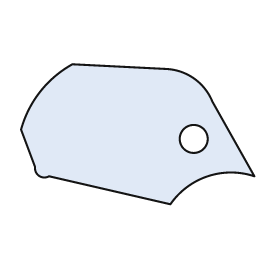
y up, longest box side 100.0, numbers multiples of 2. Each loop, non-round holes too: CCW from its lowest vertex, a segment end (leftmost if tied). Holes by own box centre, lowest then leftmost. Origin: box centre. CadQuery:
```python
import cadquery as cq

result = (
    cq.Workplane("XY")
    .moveTo(14.0, -30.0)
    .threePointArc((30.0, -18.0), (50.0, -18.0))
    .lineTo(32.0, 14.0)
    .threePointArc((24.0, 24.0), (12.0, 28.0))
    .lineTo(-28.0, 30.0)
    .threePointArc((-42.0, 18.0), (-50.0, 2.0))
    .lineTo(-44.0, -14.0)
    .threePointArc((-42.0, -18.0), (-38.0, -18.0))
    .close()
    .moveTo(24.0, -2.0)
    .circle(6.0)
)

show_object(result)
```